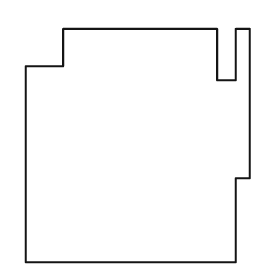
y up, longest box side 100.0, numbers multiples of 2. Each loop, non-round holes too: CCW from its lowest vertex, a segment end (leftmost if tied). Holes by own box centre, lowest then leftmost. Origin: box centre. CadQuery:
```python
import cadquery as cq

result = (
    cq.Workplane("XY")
    .moveTo(-48.0, -50.0)
    .lineTo(42.0, -50.0)
    .lineTo(42.0, -14.0)
    .lineTo(48.0, -14.0)
    .lineTo(48.0, 50.0)
    .lineTo(42.0, 50.0)
    .lineTo(42.0, 28.0)
    .lineTo(34.0, 28.0)
    .lineTo(34.0, 50.0)
    .lineTo(-32.0, 50.0)
    .lineTo(-32.0, 34.0)
    .lineTo(-48.0, 34.0)
    .close()
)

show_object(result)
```